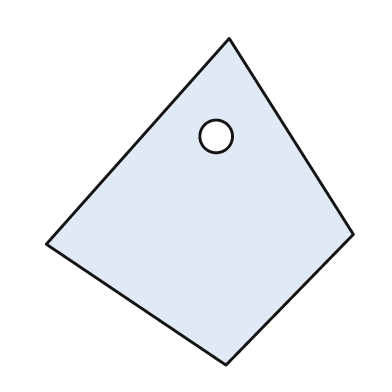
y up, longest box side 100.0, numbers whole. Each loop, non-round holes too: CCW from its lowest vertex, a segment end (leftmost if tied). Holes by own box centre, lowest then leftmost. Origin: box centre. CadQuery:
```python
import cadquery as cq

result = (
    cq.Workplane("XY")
    .moveTo(8.0, -50.0)
    .lineTo(47.0, -10.0)
    .lineTo(9.0, 50.0)
    .lineTo(-47.0, -13.0)
    .close()
    .moveTo(5.0, 20.0)
    .circle(5.0)
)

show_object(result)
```